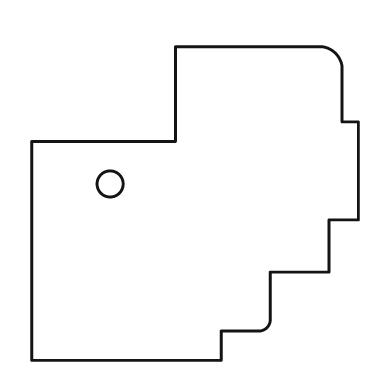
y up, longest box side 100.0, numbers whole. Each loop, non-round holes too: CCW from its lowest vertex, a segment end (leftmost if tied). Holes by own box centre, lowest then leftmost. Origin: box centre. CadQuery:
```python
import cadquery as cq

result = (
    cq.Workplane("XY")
    .moveTo(-50.0, -48.0)
    .lineTo(8.0, -48.0)
    .lineTo(8.0, -39.0)
    .lineTo(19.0, -39.0)
    .threePointArc((22.0, -38.0), (23.0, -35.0))
    .lineTo(23.0, -21.0)
    .lineTo(41.0, -21.0)
    .lineTo(41.0, -5.0)
    .lineTo(50.0, -5.0)
    .lineTo(50.0, 25.0)
    .lineTo(45.0, 25.0)
    .lineTo(45.0, 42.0)
    .threePointArc((43.0, 46.0), (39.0, 48.0))
    .lineTo(-6.0, 48.0)
    .lineTo(-6.0, 19.0)
    .lineTo(-50.0, 19.0)
    .close()
    .moveTo(-26.0, 6.0)
    .circle(4.0)
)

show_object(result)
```